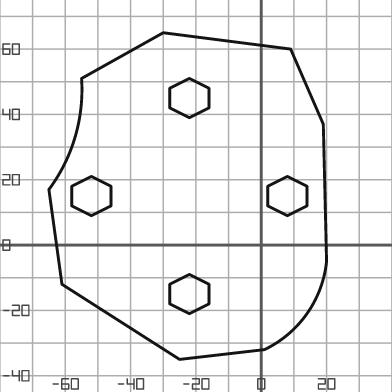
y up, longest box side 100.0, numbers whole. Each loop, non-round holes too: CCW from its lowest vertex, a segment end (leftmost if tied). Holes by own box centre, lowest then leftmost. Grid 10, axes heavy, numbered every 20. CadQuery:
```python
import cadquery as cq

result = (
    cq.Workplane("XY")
    .moveTo(-25.0, -35.0)
    .lineTo(1.0, -32.0)
    .threePointArc((14.0, -21.0), (20.0, -5.0))
    .lineTo(19.0, 37.0)
    .lineTo(9.0, 60.0)
    .lineTo(-30.0, 65.0)
    .lineTo(-55.0, 51.0)
    .threePointArc((-57.0, 33.0), (-65.0, 17.0))
    .lineTo(-61.0, -12.0)
    .close()
    .moveTo(-22.0, -21.0)
    .lineTo(-16.0, -18.0)
    .lineTo(-16.0, -12.0)
    .lineTo(-22.0, -9.0)
    .lineTo(-28.0, -12.0)
    .lineTo(-28.0, -18.0)
    .close()
    .moveTo(-52.0, 9.0)
    .lineTo(-46.0, 12.0)
    .lineTo(-46.0, 18.0)
    .lineTo(-52.0, 21.0)
    .lineTo(-58.0, 18.0)
    .lineTo(-58.0, 12.0)
    .close()
    .moveTo(8.0, 9.0)
    .lineTo(14.0, 12.0)
    .lineTo(14.0, 18.0)
    .lineTo(8.0, 21.0)
    .lineTo(2.0, 18.0)
    .lineTo(2.0, 12.0)
    .close()
    .moveTo(-22.0, 39.0)
    .lineTo(-16.0, 42.0)
    .lineTo(-16.0, 48.0)
    .lineTo(-22.0, 51.0)
    .lineTo(-28.0, 48.0)
    .lineTo(-28.0, 42.0)
    .close()
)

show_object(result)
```